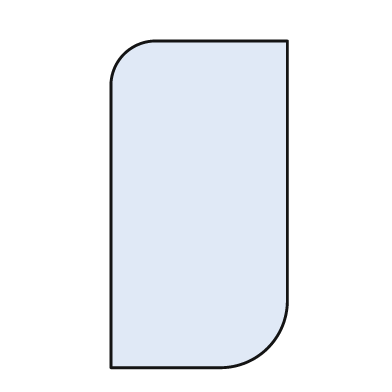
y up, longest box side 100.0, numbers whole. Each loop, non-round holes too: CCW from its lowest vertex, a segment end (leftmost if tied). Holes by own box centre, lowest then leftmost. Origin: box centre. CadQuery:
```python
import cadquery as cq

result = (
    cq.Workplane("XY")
    .moveTo(-27.0, -50.0)
    .lineTo(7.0, -50.0)
    .threePointArc((21.0, -44.0), (27.0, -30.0))
    .lineTo(27.0, 50.0)
    .lineTo(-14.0, 50.0)
    .threePointArc((-23.0, 46.0), (-27.0, 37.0))
    .close()
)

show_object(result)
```